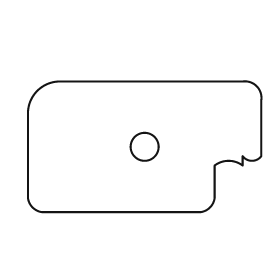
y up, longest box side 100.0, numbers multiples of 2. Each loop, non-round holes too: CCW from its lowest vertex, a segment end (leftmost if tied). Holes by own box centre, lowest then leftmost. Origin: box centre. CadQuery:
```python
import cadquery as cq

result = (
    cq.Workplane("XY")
    .moveTo(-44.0, -28.0)
    .lineTo(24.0, -28.0)
    .threePointArc((28.0, -26.0), (30.0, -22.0))
    .lineTo(30.0, -8.0)
    .threePointArc((36.0, -6.0), (42.0, -8.0))
    .lineTo(42.0, -4.0)
    .threePointArc((46.0, -6.0), (50.0, -4.0))
    .lineTo(50.0, 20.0)
    .threePointArc((48.0, 26.0), (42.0, 28.0))
    .lineTo(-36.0, 28.0)
    .threePointArc((-46.0, 24.0), (-50.0, 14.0))
    .lineTo(-50.0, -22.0)
    .threePointArc((-48.0, -26.0), (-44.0, -28.0))
    .close()
    .moveTo(0.0, 0.0)
    .circle(6.0)
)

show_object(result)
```